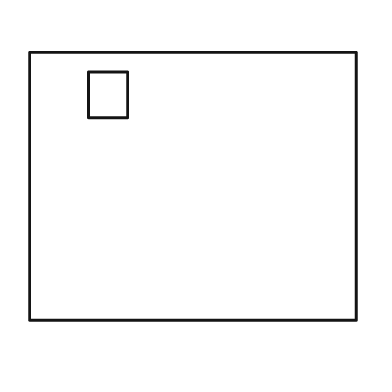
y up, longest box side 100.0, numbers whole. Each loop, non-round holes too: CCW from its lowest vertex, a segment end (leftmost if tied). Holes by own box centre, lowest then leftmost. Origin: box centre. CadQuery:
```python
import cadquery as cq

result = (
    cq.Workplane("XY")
    .moveTo(-50.0, -41.0)
    .lineTo(50.0, -41.0)
    .lineTo(50.0, 41.0)
    .lineTo(-50.0, 41.0)
    .close()
    .moveTo(-32.0, 21.0)
    .lineTo(-20.0, 21.0)
    .lineTo(-20.0, 35.0)
    .lineTo(-32.0, 35.0)
    .close()
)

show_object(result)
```